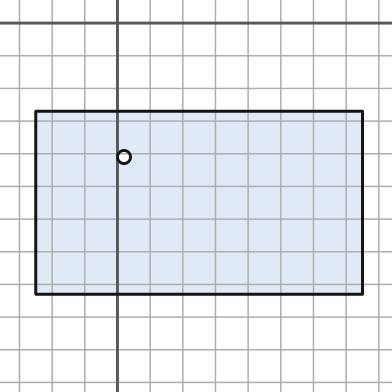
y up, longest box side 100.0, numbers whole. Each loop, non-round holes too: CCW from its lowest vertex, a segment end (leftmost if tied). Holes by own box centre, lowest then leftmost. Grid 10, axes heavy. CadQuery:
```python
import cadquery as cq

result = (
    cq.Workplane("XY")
    .moveTo(-25.0, -83.0)
    .lineTo(75.0, -83.0)
    .lineTo(75.0, -27.0)
    .lineTo(-25.0, -27.0)
    .close()
    .moveTo(2.0, -41.0)
    .circle(2.0)
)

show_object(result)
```